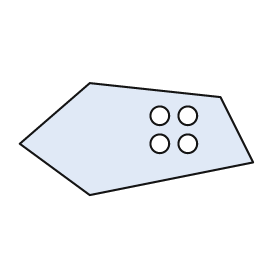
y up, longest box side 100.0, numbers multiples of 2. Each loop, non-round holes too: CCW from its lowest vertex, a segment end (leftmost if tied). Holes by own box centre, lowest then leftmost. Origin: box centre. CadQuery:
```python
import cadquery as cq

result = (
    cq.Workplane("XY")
    .moveTo(-20.0, -24.0)
    .lineTo(50.0, -10.0)
    .lineTo(36.0, 18.0)
    .lineTo(-20.0, 24.0)
    .lineTo(-50.0, -2.0)
    .close()
    .moveTo(10.0, -2.0)
    .circle(4.0)
    .moveTo(22.0, -2.0)
    .circle(4.0)
    .moveTo(10.0, 10.0)
    .circle(4.0)
    .moveTo(22.0, 10.0)
    .circle(4.0)
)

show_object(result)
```